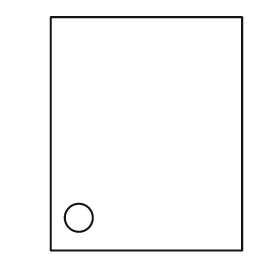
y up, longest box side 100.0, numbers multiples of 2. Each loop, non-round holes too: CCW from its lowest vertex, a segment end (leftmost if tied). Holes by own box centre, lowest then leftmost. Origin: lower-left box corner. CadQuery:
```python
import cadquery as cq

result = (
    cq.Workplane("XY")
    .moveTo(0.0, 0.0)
    .lineTo(82.0, 0.0)
    .lineTo(82.0, 100.0)
    .lineTo(0.0, 100.0)
    .close()
    .moveTo(12.0, 14.0)
    .circle(6.0)
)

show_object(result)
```